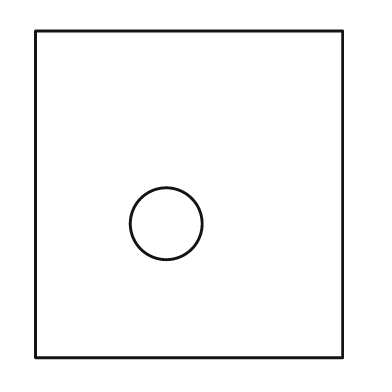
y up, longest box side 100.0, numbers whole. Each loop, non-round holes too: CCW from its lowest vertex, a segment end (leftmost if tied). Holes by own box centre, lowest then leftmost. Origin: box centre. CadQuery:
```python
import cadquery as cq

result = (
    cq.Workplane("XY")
    .moveTo(-47.0, -50.0)
    .lineTo(47.0, -50.0)
    .lineTo(47.0, 50.0)
    .lineTo(-47.0, 50.0)
    .close()
    .moveTo(-7.0, -9.0)
    .circle(11.0)
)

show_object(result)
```